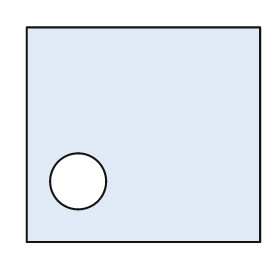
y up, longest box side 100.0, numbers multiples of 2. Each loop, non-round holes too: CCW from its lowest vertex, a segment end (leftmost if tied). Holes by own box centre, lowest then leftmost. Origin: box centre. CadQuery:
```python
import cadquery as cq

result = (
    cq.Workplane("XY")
    .moveTo(-50.0, -46.0)
    .lineTo(50.0, -46.0)
    .lineTo(50.0, 46.0)
    .lineTo(-50.0, 46.0)
    .close()
    .moveTo(-28.0, -20.0)
    .circle(12.0)
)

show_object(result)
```